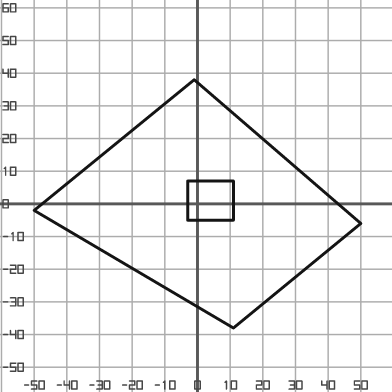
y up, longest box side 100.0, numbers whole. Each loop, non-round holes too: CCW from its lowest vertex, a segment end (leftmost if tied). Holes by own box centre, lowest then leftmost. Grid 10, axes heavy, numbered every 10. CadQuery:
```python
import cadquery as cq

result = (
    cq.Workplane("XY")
    .moveTo(11.0, -38.0)
    .lineTo(50.0, -6.0)
    .lineTo(-1.0, 38.0)
    .lineTo(-50.0, -2.0)
    .close()
    .moveTo(-3.0, -5.0)
    .lineTo(11.0, -5.0)
    .lineTo(11.0, 7.0)
    .lineTo(-3.0, 7.0)
    .close()
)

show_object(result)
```